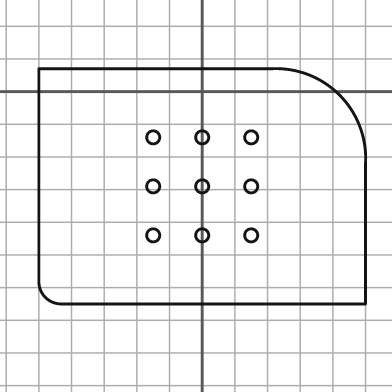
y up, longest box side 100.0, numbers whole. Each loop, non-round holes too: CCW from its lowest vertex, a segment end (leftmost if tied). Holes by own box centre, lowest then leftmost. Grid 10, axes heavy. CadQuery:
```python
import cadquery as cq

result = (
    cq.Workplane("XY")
    .moveTo(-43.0, -65.0)
    .lineTo(50.0, -65.0)
    .lineTo(50.0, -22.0)
    .threePointArc((42.0, -1.0), (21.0, 7.0))
    .lineTo(-50.0, 7.0)
    .lineTo(-50.0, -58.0)
    .threePointArc((-48.0, -63.0), (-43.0, -65.0))
    .close()
    .moveTo(-15.0, -44.0)
    .circle(2.0)
    .moveTo(0.0, -44.0)
    .circle(2.0)
    .moveTo(15.0, -44.0)
    .circle(2.0)
    .moveTo(-15.0, -29.0)
    .circle(2.0)
    .moveTo(0.0, -29.0)
    .circle(2.0)
    .moveTo(15.0, -29.0)
    .circle(2.0)
    .moveTo(-15.0, -14.0)
    .circle(2.0)
    .moveTo(0.0, -14.0)
    .circle(2.0)
    .moveTo(15.0, -14.0)
    .circle(2.0)
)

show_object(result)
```